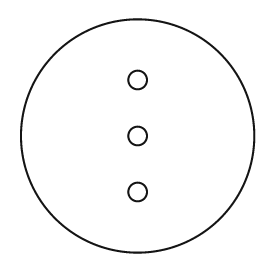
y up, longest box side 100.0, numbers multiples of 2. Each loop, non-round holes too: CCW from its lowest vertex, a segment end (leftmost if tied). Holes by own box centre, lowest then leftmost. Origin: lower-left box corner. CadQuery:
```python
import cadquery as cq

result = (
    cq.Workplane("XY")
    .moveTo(50.0, 50.0)
    .circle(50.0)
    .moveTo(50.0, 26.0)
    .circle(4.0)
    .moveTo(50.0, 50.0)
    .circle(4.0)
    .moveTo(50.0, 74.0)
    .circle(4.0)
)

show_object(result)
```